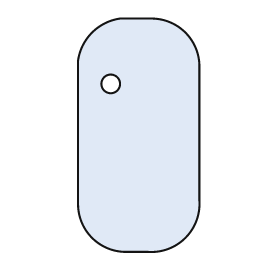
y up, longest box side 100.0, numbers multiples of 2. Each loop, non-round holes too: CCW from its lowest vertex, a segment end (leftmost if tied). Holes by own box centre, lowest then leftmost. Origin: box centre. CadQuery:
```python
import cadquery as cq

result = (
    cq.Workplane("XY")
    .moveTo(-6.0, -50.0)
    .lineTo(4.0, -50.0)
    .threePointArc((20.0, -44.0), (26.0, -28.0))
    .lineTo(26.0, 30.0)
    .threePointArc((20.0, 44.0), (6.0, 50.0))
    .lineTo(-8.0, 50.0)
    .threePointArc((-20.0, 44.0), (-26.0, 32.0))
    .lineTo(-26.0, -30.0)
    .threePointArc((-20.0, -44.0), (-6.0, -50.0))
    .close()
    .moveTo(-12.0, 22.0)
    .circle(4.0)
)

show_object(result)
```